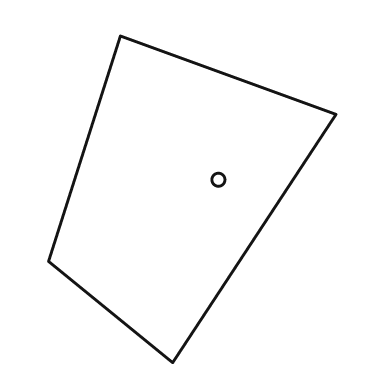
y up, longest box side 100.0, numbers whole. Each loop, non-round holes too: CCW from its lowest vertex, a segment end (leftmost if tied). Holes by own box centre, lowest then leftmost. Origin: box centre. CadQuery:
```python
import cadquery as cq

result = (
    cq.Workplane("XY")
    .moveTo(-6.0, -50.0)
    .lineTo(44.0, 26.0)
    .lineTo(-22.0, 50.0)
    .lineTo(-44.0, -19.0)
    .close()
    .moveTo(8.0, 6.0)
    .circle(2.0)
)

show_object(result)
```